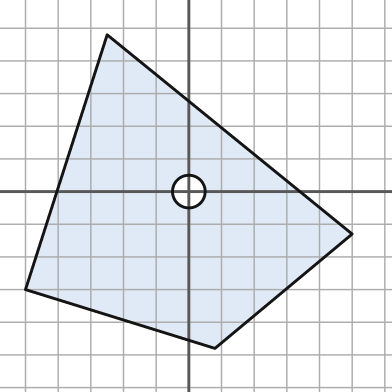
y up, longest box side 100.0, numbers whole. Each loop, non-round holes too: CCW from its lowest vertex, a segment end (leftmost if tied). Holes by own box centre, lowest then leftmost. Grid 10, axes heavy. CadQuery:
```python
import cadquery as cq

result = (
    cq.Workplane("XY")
    .moveTo(8.0, -48.0)
    .lineTo(50.0, -13.0)
    .lineTo(-25.0, 48.0)
    .lineTo(-50.0, -30.0)
    .close()
    .moveTo(0.0, 0.0)
    .circle(5.0)
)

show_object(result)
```